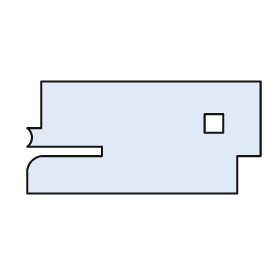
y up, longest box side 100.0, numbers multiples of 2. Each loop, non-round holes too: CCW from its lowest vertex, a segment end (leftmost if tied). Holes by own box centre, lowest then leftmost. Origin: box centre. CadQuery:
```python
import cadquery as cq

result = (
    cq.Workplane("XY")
    .moveTo(-50.0, -24.0)
    .lineTo(40.0, -24.0)
    .lineTo(40.0, -8.0)
    .lineTo(50.0, -8.0)
    .lineTo(50.0, 24.0)
    .lineTo(-44.0, 24.0)
    .lineTo(-44.0, 4.0)
    .lineTo(-50.0, 4.0)
    .threePointArc((-48.0, 0.0), (-50.0, -4.0))
    .lineTo(-18.0, -4.0)
    .lineTo(-18.0, -8.0)
    .lineTo(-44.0, -8.0)
    .threePointArc((-48.0, -10.0), (-50.0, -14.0))
    .close()
    .moveTo(26.0, 2.0)
    .lineTo(34.0, 2.0)
    .lineTo(34.0, 10.0)
    .lineTo(26.0, 10.0)
    .close()
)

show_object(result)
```